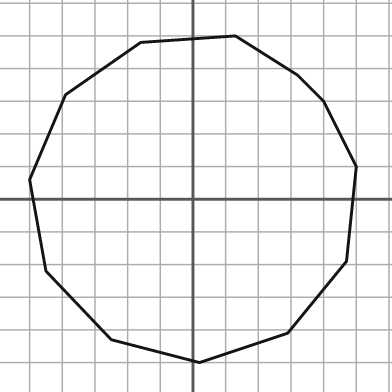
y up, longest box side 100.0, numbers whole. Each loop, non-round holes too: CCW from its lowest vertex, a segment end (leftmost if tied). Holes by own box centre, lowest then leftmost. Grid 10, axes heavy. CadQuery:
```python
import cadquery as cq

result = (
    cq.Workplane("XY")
    .moveTo(2.0, -50.0)
    .lineTo(29.0, -41.0)
    .lineTo(47.0, -19.0)
    .lineTo(50.0, 10.0)
    .lineTo(40.0, 30.0)
    .lineTo(32.0, 38.0)
    .lineTo(13.0, 50.0)
    .lineTo(-16.0, 48.0)
    .lineTo(-39.0, 32.0)
    .lineTo(-50.0, 6.0)
    .lineTo(-45.0, -22.0)
    .lineTo(-25.0, -43.0)
    .close()
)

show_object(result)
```